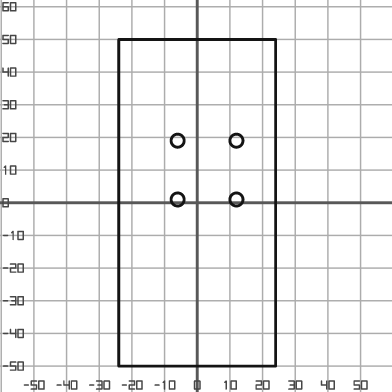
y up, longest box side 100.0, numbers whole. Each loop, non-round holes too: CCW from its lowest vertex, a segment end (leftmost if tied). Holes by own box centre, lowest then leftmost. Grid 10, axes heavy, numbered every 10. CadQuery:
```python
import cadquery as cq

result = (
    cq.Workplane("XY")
    .moveTo(-24.0, -50.0)
    .lineTo(24.0, -50.0)
    .lineTo(24.0, 50.0)
    .lineTo(-24.0, 50.0)
    .close()
    .moveTo(-6.0, 1.0)
    .circle(2.0)
    .moveTo(12.0, 1.0)
    .circle(2.0)
    .moveTo(-6.0, 19.0)
    .circle(2.0)
    .moveTo(12.0, 19.0)
    .circle(2.0)
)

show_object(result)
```